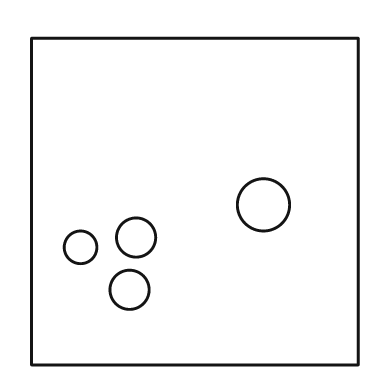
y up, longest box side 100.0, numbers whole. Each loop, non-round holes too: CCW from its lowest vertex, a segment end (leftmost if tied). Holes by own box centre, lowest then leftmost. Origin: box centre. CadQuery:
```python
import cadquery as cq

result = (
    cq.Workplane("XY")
    .moveTo(-50.0, -50.0)
    .lineTo(50.0, -50.0)
    .lineTo(50.0, 50.0)
    .lineTo(-50.0, 50.0)
    .close()
    .moveTo(-20.0, -27.0)
    .circle(6.0)
    .moveTo(-35.0, -14.0)
    .circle(5.0)
    .moveTo(-18.0, -11.0)
    .circle(6.0)
    .moveTo(21.0, -1.0)
    .circle(8.0)
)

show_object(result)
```